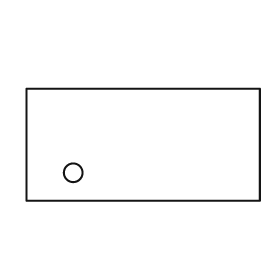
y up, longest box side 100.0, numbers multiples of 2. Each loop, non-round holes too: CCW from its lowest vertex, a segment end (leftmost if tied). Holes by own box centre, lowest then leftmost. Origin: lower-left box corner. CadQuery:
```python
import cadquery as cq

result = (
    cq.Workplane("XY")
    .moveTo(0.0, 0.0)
    .lineTo(100.0, 0.0)
    .lineTo(100.0, 48.0)
    .lineTo(0.0, 48.0)
    .close()
    .moveTo(20.0, 12.0)
    .circle(4.0)
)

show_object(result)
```